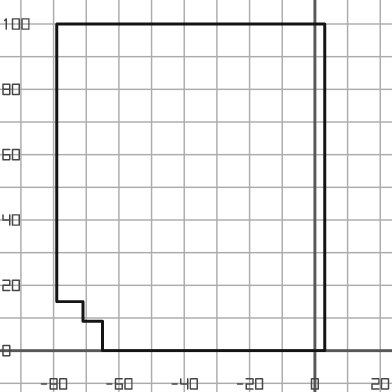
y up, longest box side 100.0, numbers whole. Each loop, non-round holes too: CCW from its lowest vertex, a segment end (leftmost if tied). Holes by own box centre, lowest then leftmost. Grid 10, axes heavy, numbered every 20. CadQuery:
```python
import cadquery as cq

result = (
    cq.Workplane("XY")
    .moveTo(-65.0, 0.0)
    .lineTo(3.0, 0.0)
    .lineTo(3.0, 100.0)
    .lineTo(-79.0, 100.0)
    .lineTo(-79.0, 15.0)
    .lineTo(-71.0, 15.0)
    .lineTo(-71.0, 9.0)
    .lineTo(-65.0, 9.0)
    .close()
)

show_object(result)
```